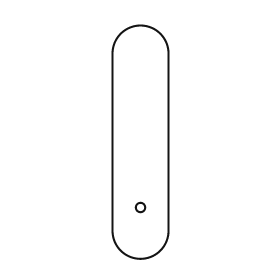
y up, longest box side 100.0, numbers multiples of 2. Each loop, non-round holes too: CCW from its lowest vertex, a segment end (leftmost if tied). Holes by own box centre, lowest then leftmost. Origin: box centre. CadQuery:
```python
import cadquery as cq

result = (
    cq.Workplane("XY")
    .moveTo(-12.0, -38.0)
    .threePointArc((0.0, -50.0), (12.0, -38.0))
    .lineTo(12.0, 38.0)
    .threePointArc((0.0, 50.0), (-12.0, 38.0))
    .close()
    .moveTo(0.0, -28.0)
    .circle(2.0)
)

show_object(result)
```